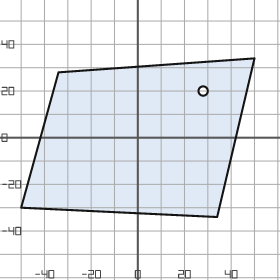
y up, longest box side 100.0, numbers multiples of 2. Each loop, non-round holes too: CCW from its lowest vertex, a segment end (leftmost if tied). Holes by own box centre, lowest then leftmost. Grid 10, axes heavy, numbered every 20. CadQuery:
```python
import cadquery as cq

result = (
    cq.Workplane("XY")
    .moveTo(34.0, -34.0)
    .lineTo(50.0, 34.0)
    .lineTo(-34.0, 28.0)
    .lineTo(-50.0, -30.0)
    .close()
    .moveTo(28.0, 20.0)
    .circle(2.0)
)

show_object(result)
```